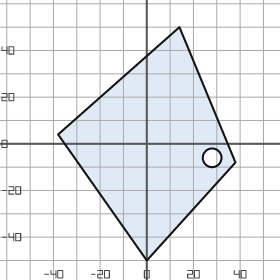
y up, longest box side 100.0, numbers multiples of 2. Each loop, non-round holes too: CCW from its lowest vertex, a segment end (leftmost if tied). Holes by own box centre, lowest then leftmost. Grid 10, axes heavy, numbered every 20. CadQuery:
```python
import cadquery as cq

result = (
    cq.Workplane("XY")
    .moveTo(0.0, -50.0)
    .lineTo(38.0, -8.0)
    .lineTo(14.0, 50.0)
    .lineTo(-38.0, 4.0)
    .close()
    .moveTo(28.0, -6.0)
    .circle(4.0)
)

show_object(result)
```